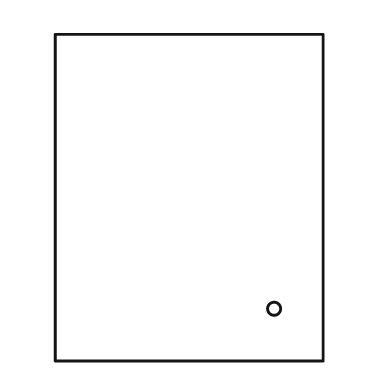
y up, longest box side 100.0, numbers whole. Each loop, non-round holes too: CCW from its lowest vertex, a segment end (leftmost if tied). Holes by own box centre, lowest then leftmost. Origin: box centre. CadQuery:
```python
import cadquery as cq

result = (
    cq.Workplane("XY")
    .moveTo(-41.0, -50.0)
    .lineTo(41.0, -50.0)
    .lineTo(41.0, 50.0)
    .lineTo(-41.0, 50.0)
    .close()
    .moveTo(26.0, -34.0)
    .circle(2.0)
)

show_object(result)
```